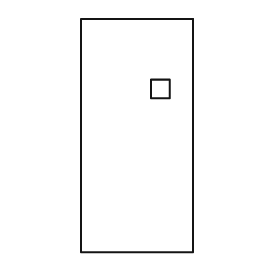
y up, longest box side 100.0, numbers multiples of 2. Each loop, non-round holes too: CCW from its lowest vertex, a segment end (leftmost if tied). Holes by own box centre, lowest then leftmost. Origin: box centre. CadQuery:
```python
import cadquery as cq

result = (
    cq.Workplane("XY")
    .moveTo(-24.0, -50.0)
    .lineTo(24.0, -50.0)
    .lineTo(24.0, 50.0)
    .lineTo(-24.0, 50.0)
    .close()
    .moveTo(6.0, 16.0)
    .lineTo(14.0, 16.0)
    .lineTo(14.0, 24.0)
    .lineTo(6.0, 24.0)
    .close()
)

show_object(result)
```